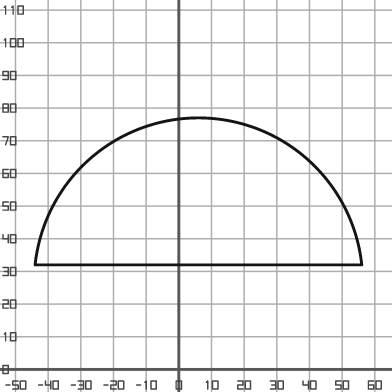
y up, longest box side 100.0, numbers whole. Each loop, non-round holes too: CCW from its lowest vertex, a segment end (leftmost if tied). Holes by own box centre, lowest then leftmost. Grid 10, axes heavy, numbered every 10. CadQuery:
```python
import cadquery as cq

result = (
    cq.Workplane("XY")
    .moveTo(-44.0, 32.0)
    .lineTo(56.0, 32.0)
    .threePointArc((6.0, 77.0), (-44.0, 32.0))
    .close()
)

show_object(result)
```